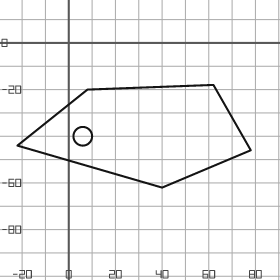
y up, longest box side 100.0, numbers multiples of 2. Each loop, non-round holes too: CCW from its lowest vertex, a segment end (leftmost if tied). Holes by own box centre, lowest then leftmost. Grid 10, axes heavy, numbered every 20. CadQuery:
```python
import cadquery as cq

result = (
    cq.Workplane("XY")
    .moveTo(40.0, -62.0)
    .lineTo(78.0, -46.0)
    .lineTo(62.0, -18.0)
    .lineTo(8.0, -20.0)
    .lineTo(-22.0, -44.0)
    .close()
    .moveTo(6.0, -40.0)
    .circle(4.0)
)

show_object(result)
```